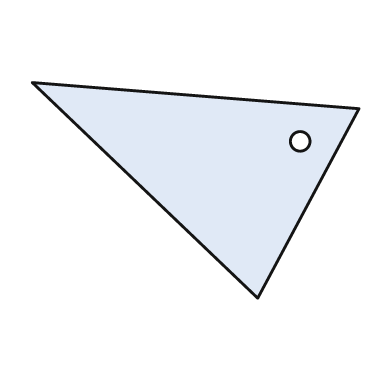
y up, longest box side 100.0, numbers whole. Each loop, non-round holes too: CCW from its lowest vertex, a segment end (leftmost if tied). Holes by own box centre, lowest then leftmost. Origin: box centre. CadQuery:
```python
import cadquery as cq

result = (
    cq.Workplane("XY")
    .moveTo(19.0, -33.0)
    .lineTo(50.0, 25.0)
    .lineTo(-50.0, 33.0)
    .close()
    .moveTo(32.0, 15.0)
    .circle(3.0)
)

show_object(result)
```